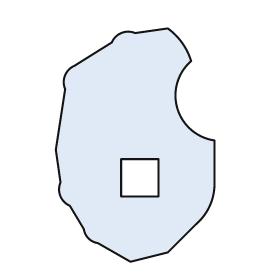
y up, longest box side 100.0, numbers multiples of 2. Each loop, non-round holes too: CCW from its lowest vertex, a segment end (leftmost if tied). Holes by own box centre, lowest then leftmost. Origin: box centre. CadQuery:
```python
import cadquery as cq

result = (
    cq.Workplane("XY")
    .moveTo(-2.0, -50.0)
    .lineTo(14.0, -46.0)
    .lineTo(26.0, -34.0)
    .threePointArc((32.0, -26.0), (34.0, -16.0))
    .lineTo(34.0, 2.0)
    .threePointArc((18.0, 16.0), (24.0, 36.0))
    .threePointArc((20.0, 44.0), (14.0, 50.0))
    .lineTo(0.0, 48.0)
    .threePointArc((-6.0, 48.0), (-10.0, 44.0))
    .lineTo(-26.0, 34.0)
    .threePointArc((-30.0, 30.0), (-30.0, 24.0))
    .lineTo(-34.0, -2.0)
    .lineTo(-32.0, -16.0)
    .threePointArc((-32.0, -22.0), (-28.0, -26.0))
    .lineTo(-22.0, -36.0)
    .threePointArc((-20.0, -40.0), (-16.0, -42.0))
    .close()
    .moveTo(-6.0, -22.0)
    .lineTo(10.0, -22.0)
    .lineTo(10.0, -6.0)
    .lineTo(-6.0, -6.0)
    .close()
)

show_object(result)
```